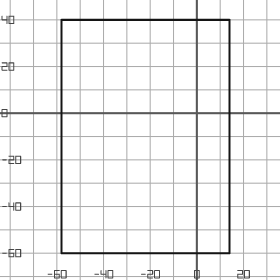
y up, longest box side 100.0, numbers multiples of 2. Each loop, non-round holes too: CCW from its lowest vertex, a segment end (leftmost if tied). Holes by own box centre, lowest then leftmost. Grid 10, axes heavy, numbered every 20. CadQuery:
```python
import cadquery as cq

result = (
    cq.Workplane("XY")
    .moveTo(-58.0, -60.0)
    .lineTo(14.0, -60.0)
    .lineTo(14.0, 40.0)
    .lineTo(-58.0, 40.0)
    .close()
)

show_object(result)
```